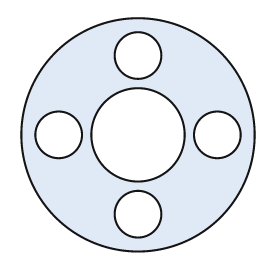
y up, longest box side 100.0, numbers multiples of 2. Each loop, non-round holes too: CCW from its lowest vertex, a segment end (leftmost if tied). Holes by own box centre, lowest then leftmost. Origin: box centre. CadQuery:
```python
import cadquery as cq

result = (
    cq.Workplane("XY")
    .moveTo(0.0, 0.0)
    .circle(50.0)
    .moveTo(0.0, -34.0)
    .circle(10.0)
    .moveTo(-34.0, 0.0)
    .circle(10.0)
    .moveTo(0.0, 0.0)
    .circle(20.0)
    .moveTo(34.0, 0.0)
    .circle(10.0)
    .moveTo(0.0, 34.0)
    .circle(10.0)
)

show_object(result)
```